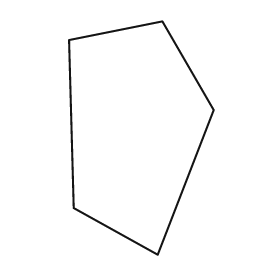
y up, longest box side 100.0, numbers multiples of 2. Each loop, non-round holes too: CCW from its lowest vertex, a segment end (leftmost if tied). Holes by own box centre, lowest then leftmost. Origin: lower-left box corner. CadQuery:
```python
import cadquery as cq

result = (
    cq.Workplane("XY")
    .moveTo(38.0, 0.0)
    .lineTo(62.0, 62.0)
    .lineTo(40.0, 100.0)
    .lineTo(0.0, 92.0)
    .lineTo(2.0, 20.0)
    .close()
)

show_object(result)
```